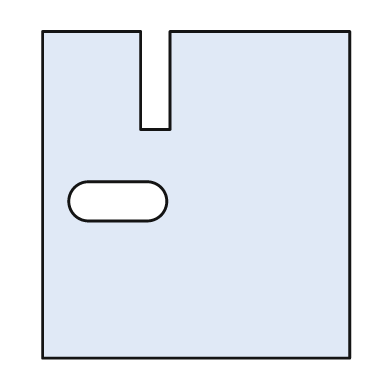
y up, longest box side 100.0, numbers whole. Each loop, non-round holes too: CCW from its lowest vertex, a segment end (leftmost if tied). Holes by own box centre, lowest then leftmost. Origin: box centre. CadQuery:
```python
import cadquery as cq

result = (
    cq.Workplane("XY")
    .moveTo(-47.0, -50.0)
    .lineTo(47.0, -50.0)
    .lineTo(47.0, 50.0)
    .lineTo(-8.0, 50.0)
    .lineTo(-8.0, 20.0)
    .lineTo(-17.0, 20.0)
    .lineTo(-17.0, 50.0)
    .lineTo(-47.0, 50.0)
    .close()
    .moveTo(-33.0, -8.0)
    .lineTo(-15.0, -8.0)
    .threePointArc((-9.0, -2.0), (-15.0, 4.0))
    .lineTo(-33.0, 4.0)
    .threePointArc((-39.0, -2.0), (-33.0, -8.0))
    .close()
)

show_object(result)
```